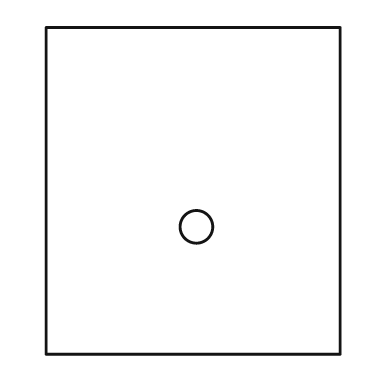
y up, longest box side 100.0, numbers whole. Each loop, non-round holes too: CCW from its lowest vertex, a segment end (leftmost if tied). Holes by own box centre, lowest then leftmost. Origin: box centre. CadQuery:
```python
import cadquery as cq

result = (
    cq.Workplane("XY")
    .moveTo(-45.0, -50.0)
    .lineTo(45.0, -50.0)
    .lineTo(45.0, 50.0)
    .lineTo(-45.0, 50.0)
    .close()
    .moveTo(1.0, -11.0)
    .circle(5.0)
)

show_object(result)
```